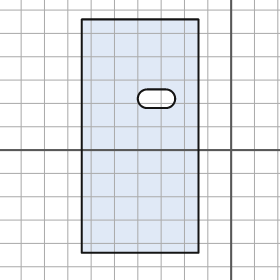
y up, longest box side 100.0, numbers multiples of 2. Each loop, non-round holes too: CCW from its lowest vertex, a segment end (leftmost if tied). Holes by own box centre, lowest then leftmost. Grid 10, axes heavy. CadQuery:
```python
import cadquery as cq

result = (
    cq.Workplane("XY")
    .moveTo(-64.0, -44.0)
    .lineTo(-14.0, -44.0)
    .lineTo(-14.0, 56.0)
    .lineTo(-64.0, 56.0)
    .close()
    .moveTo(-36.0, 18.0)
    .lineTo(-28.0, 18.0)
    .threePointArc((-24.0, 22.0), (-28.0, 26.0))
    .lineTo(-36.0, 26.0)
    .threePointArc((-40.0, 22.0), (-36.0, 18.0))
    .close()
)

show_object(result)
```